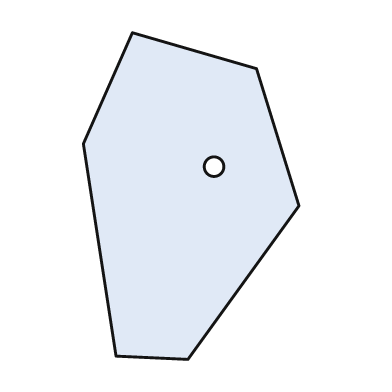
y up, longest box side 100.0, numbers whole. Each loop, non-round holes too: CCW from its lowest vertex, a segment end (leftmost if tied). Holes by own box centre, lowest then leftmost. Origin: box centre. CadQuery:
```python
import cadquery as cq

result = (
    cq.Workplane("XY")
    .moveTo(-1.0, -50.0)
    .lineTo(33.0, -3.0)
    .lineTo(20.0, 39.0)
    .lineTo(-18.0, 50.0)
    .lineTo(-33.0, 16.0)
    .lineTo(-23.0, -49.0)
    .close()
    .moveTo(7.0, 9.0)
    .circle(3.0)
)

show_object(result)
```